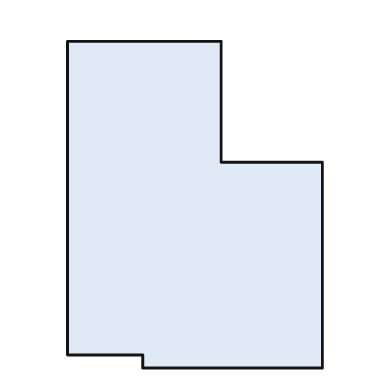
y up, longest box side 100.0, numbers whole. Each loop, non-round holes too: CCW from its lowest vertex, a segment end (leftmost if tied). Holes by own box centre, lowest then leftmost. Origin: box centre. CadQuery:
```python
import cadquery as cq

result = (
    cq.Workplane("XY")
    .moveTo(-16.0, -50.0)
    .lineTo(39.0, -50.0)
    .lineTo(39.0, 13.0)
    .lineTo(8.0, 13.0)
    .lineTo(8.0, 50.0)
    .lineTo(-39.0, 50.0)
    .lineTo(-39.0, -46.0)
    .lineTo(-16.0, -46.0)
    .close()
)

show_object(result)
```